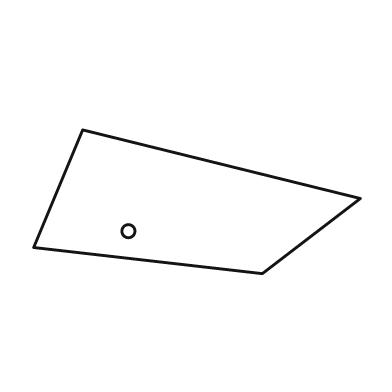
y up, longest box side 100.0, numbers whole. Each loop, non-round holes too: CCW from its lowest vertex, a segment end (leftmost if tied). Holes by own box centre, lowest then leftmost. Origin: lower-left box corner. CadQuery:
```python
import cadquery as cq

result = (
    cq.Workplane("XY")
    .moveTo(70.0, 0.0)
    .lineTo(100.0, 23.0)
    .lineTo(15.0, 44.0)
    .lineTo(0.0, 8.0)
    .close()
    .moveTo(29.0, 13.0)
    .circle(2.0)
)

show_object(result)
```